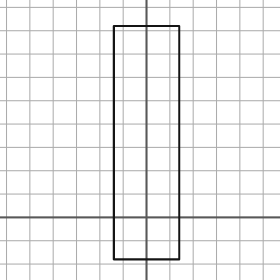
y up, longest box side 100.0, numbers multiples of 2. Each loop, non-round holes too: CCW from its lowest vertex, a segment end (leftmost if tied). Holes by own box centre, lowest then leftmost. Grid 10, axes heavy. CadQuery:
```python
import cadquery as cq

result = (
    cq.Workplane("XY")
    .moveTo(-14.0, -18.0)
    .lineTo(14.0, -18.0)
    .lineTo(14.0, 82.0)
    .lineTo(-14.0, 82.0)
    .close()
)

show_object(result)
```